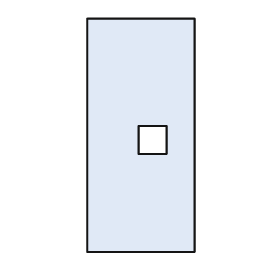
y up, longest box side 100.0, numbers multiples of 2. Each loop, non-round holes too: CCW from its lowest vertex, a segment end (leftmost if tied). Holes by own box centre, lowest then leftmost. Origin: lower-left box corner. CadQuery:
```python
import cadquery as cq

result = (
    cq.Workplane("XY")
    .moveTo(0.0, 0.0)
    .lineTo(46.0, 0.0)
    .lineTo(46.0, 100.0)
    .lineTo(0.0, 100.0)
    .close()
    .moveTo(22.0, 42.0)
    .lineTo(34.0, 42.0)
    .lineTo(34.0, 54.0)
    .lineTo(22.0, 54.0)
    .close()
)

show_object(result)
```